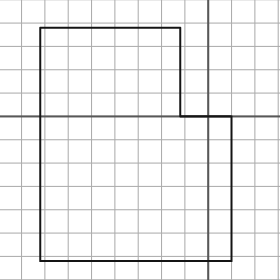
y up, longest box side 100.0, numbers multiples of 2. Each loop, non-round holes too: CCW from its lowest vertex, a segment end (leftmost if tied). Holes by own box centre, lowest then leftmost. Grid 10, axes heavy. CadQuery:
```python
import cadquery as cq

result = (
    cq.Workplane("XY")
    .moveTo(-72.0, -62.0)
    .lineTo(10.0, -62.0)
    .lineTo(10.0, 0.0)
    .lineTo(-12.0, 0.0)
    .lineTo(-12.0, 38.0)
    .lineTo(-72.0, 38.0)
    .close()
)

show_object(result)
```